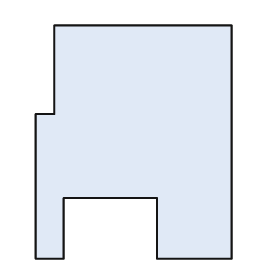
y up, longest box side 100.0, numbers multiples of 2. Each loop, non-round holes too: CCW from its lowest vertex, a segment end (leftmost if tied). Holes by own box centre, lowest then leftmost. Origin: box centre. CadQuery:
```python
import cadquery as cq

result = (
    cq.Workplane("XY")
    .moveTo(-42.0, -50.0)
    .lineTo(-30.0, -50.0)
    .lineTo(-30.0, -24.0)
    .lineTo(10.0, -24.0)
    .lineTo(10.0, -50.0)
    .lineTo(42.0, -50.0)
    .lineTo(42.0, 50.0)
    .lineTo(-34.0, 50.0)
    .lineTo(-34.0, 12.0)
    .lineTo(-42.0, 12.0)
    .close()
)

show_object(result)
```